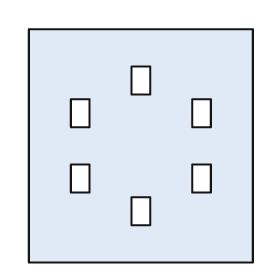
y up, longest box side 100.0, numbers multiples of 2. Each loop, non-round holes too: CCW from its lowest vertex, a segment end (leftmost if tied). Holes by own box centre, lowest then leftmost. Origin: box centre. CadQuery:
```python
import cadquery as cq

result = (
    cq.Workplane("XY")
    .moveTo(-48.0, -50.0)
    .lineTo(48.0, -50.0)
    .lineTo(48.0, 50.0)
    .lineTo(-48.0, 50.0)
    .close()
    .moveTo(-4.0, -34.0)
    .lineTo(4.0, -34.0)
    .lineTo(4.0, -22.0)
    .lineTo(-4.0, -22.0)
    .close()
    .moveTo(-30.0, -20.0)
    .lineTo(-22.0, -20.0)
    .lineTo(-22.0, -8.0)
    .lineTo(-30.0, -8.0)
    .close()
    .moveTo(22.0, -20.0)
    .lineTo(30.0, -20.0)
    .lineTo(30.0, -8.0)
    .lineTo(22.0, -8.0)
    .close()
    .moveTo(-30.0, 8.0)
    .lineTo(-22.0, 8.0)
    .lineTo(-22.0, 20.0)
    .lineTo(-30.0, 20.0)
    .close()
    .moveTo(22.0, 8.0)
    .lineTo(30.0, 8.0)
    .lineTo(30.0, 20.0)
    .lineTo(22.0, 20.0)
    .close()
    .moveTo(-4.0, 22.0)
    .lineTo(4.0, 22.0)
    .lineTo(4.0, 34.0)
    .lineTo(-4.0, 34.0)
    .close()
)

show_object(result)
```